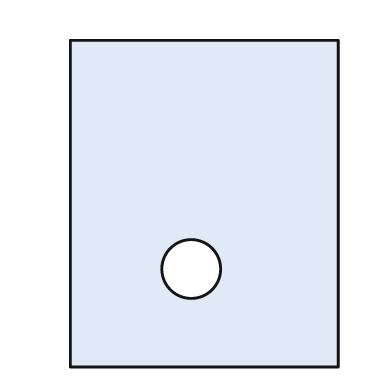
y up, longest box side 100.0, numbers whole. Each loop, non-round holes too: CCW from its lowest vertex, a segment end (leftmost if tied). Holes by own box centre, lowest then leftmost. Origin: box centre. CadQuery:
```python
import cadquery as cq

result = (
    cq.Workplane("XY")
    .moveTo(-41.0, -50.0)
    .lineTo(41.0, -50.0)
    .lineTo(41.0, 50.0)
    .lineTo(-41.0, 50.0)
    .close()
    .moveTo(-4.0, -20.0)
    .circle(9.0)
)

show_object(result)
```